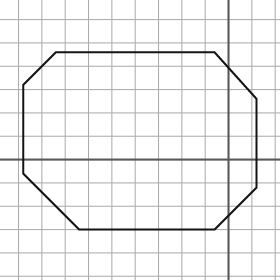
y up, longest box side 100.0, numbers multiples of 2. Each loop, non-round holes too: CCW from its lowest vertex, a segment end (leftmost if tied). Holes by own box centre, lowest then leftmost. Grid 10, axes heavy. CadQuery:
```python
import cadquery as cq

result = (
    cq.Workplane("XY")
    .moveTo(-64.0, -30.0)
    .lineTo(-6.0, -30.0)
    .lineTo(12.0, -12.0)
    .lineTo(12.0, 26.0)
    .lineTo(-6.0, 46.0)
    .lineTo(-74.0, 46.0)
    .lineTo(-88.0, 32.0)
    .lineTo(-88.0, -6.0)
    .close()
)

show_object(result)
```